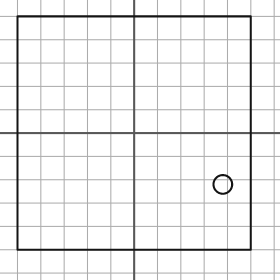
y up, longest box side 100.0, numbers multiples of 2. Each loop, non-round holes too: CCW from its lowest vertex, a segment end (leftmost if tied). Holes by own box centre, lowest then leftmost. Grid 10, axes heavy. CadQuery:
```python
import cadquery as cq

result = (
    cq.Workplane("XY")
    .moveTo(-50.0, -50.0)
    .lineTo(50.0, -50.0)
    .lineTo(50.0, 50.0)
    .lineTo(-50.0, 50.0)
    .close()
    .moveTo(38.0, -22.0)
    .circle(4.0)
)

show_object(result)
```